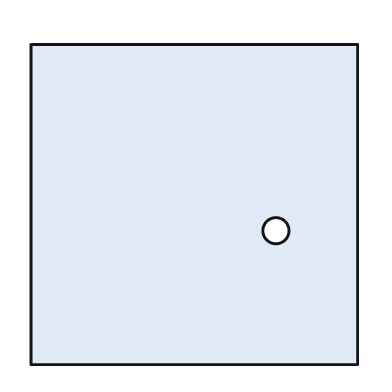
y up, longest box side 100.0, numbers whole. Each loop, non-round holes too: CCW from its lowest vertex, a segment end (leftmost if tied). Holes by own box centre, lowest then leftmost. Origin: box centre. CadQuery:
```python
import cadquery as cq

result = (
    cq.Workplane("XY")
    .moveTo(-50.0, -49.0)
    .lineTo(50.0, -49.0)
    .lineTo(50.0, 49.0)
    .lineTo(-50.0, 49.0)
    .close()
    .moveTo(25.0, -8.0)
    .circle(4.0)
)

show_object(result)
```